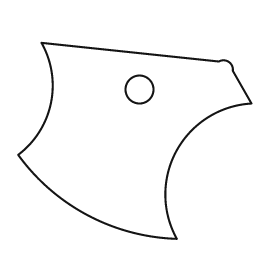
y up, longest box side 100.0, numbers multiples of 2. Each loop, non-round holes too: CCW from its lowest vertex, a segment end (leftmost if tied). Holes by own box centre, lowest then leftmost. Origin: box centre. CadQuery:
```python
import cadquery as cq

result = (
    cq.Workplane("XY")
    .moveTo(18.0, -42.0)
    .threePointArc((18.0, -4.0), (50.0, 16.0))
    .lineTo(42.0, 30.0)
    .threePointArc((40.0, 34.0), (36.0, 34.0))
    .lineTo(-40.0, 42.0)
    .threePointArc((-36.0, 16.0), (-50.0, -6.0))
    .threePointArc((-20.0, -32.0), (18.0, -42.0))
    .close()
    .moveTo(2.0, 22.0)
    .circle(6.0)
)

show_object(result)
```